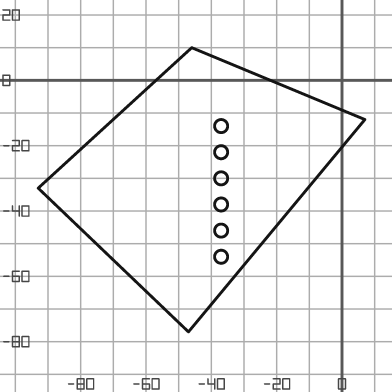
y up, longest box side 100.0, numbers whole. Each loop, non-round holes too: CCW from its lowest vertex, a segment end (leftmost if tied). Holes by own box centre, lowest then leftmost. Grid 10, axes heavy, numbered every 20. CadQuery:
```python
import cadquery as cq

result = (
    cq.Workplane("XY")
    .moveTo(-47.0, -77.0)
    .lineTo(7.0, -12.0)
    .lineTo(-46.0, 10.0)
    .lineTo(-93.0, -33.0)
    .close()
    .moveTo(-37.0, -54.0)
    .circle(2.0)
    .moveTo(-37.0, -46.0)
    .circle(2.0)
    .moveTo(-37.0, -38.0)
    .circle(2.0)
    .moveTo(-37.0, -30.0)
    .circle(2.0)
    .moveTo(-37.0, -22.0)
    .circle(2.0)
    .moveTo(-37.0, -14.0)
    .circle(2.0)
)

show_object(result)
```